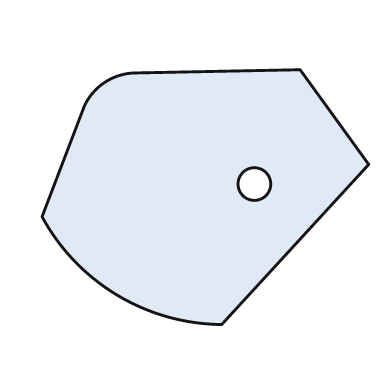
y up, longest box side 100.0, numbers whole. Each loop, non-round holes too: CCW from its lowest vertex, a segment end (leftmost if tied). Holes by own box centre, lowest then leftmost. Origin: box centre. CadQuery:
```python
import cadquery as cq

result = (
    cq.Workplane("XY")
    .moveTo(5.0, -39.0)
    .lineTo(50.0, 10.0)
    .lineTo(29.0, 39.0)
    .lineTo(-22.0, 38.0)
    .threePointArc((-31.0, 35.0), (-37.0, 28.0))
    .lineTo(-50.0, -6.0)
    .threePointArc((-27.0, -30.0), (5.0, -39.0))
    .close()
    .moveTo(15.0, 4.0)
    .circle(5.0)
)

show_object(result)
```